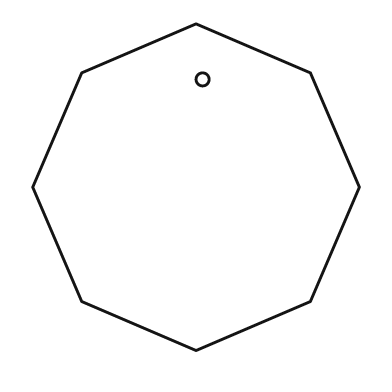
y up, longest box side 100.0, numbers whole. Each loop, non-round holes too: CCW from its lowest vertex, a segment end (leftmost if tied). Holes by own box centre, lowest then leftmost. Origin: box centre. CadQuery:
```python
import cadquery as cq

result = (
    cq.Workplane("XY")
    .moveTo(0.0, -50.0)
    .lineTo(35.0, -35.0)
    .lineTo(50.0, 0.0)
    .lineTo(35.0, 35.0)
    .lineTo(0.0, 50.0)
    .lineTo(-35.0, 35.0)
    .lineTo(-50.0, 0.0)
    .lineTo(-35.0, -35.0)
    .close()
    .moveTo(2.0, 33.0)
    .circle(2.0)
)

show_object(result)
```